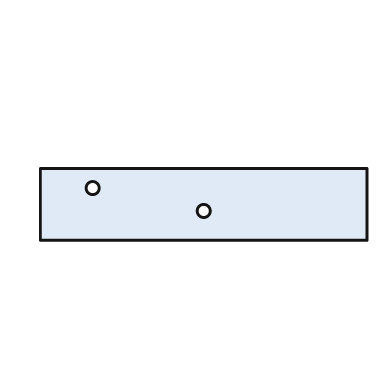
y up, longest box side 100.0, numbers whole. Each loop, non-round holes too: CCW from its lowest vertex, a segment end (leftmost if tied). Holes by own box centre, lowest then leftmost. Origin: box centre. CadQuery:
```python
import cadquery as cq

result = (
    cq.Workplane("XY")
    .moveTo(-50.0, -11.0)
    .lineTo(50.0, -11.0)
    .lineTo(50.0, 11.0)
    .lineTo(-50.0, 11.0)
    .close()
    .moveTo(0.0, -2.0)
    .circle(2.0)
    .moveTo(-34.0, 5.0)
    .circle(2.0)
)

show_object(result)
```